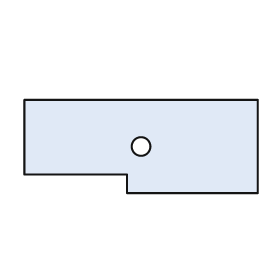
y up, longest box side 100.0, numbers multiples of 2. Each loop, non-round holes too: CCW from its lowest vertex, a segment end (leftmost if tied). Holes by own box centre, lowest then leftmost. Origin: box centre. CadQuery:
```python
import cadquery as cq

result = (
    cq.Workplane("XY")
    .moveTo(-6.0, -20.0)
    .lineTo(50.0, -20.0)
    .lineTo(50.0, 20.0)
    .lineTo(-50.0, 20.0)
    .lineTo(-50.0, -12.0)
    .lineTo(-6.0, -12.0)
    .close()
    .moveTo(0.0, 0.0)
    .circle(4.0)
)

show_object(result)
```